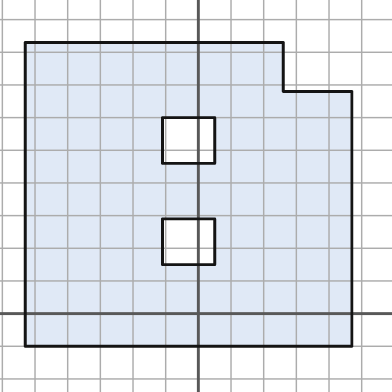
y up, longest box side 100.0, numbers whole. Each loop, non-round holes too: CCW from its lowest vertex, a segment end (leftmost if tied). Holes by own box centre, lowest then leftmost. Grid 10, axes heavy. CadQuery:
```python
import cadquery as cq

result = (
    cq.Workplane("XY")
    .moveTo(-53.0, -10.0)
    .lineTo(47.0, -10.0)
    .lineTo(47.0, 68.0)
    .lineTo(26.0, 68.0)
    .lineTo(26.0, 83.0)
    .lineTo(-53.0, 83.0)
    .close()
    .moveTo(-11.0, 15.0)
    .lineTo(5.0, 15.0)
    .lineTo(5.0, 29.0)
    .lineTo(-11.0, 29.0)
    .close()
    .moveTo(-11.0, 46.0)
    .lineTo(5.0, 46.0)
    .lineTo(5.0, 60.0)
    .lineTo(-11.0, 60.0)
    .close()
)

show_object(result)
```